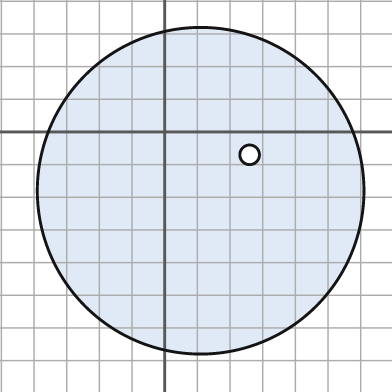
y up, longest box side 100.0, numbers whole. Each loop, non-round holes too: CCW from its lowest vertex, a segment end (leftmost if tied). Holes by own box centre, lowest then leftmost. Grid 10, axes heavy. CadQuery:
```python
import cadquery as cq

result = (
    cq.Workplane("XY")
    .moveTo(11.0, -18.0)
    .circle(50.0)
    .moveTo(26.0, -7.0)
    .circle(3.0)
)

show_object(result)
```